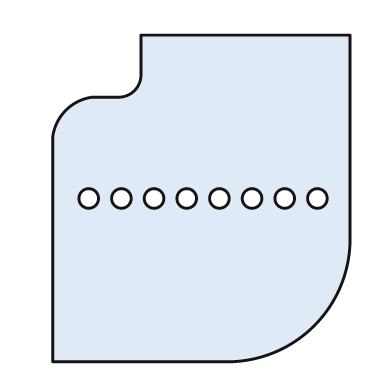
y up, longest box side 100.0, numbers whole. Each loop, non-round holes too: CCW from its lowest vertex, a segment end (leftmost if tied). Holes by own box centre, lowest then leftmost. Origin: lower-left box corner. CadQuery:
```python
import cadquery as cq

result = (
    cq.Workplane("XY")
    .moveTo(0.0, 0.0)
    .lineTo(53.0, 0.0)
    .threePointArc((80.0, 11.0), (91.0, 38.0))
    .lineTo(91.0, 100.0)
    .lineTo(27.0, 100.0)
    .lineTo(27.0, 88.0)
    .threePointArc((25.0, 83.0), (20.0, 81.0))
    .lineTo(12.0, 81.0)
    .threePointArc((4.0, 77.0), (0.0, 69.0))
    .close()
    .moveTo(11.0, 50.0)
    .circle(3.0)
    .moveTo(21.0, 50.0)
    .circle(3.0)
    .moveTo(31.0, 50.0)
    .circle(3.0)
    .moveTo(41.0, 50.0)
    .circle(3.0)
    .moveTo(51.0, 50.0)
    .circle(3.0)
    .moveTo(61.0, 50.0)
    .circle(3.0)
    .moveTo(71.0, 50.0)
    .circle(3.0)
    .moveTo(81.0, 50.0)
    .circle(3.0)
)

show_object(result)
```